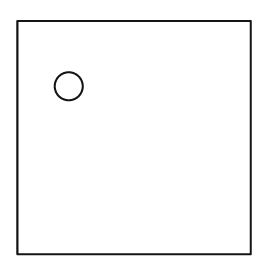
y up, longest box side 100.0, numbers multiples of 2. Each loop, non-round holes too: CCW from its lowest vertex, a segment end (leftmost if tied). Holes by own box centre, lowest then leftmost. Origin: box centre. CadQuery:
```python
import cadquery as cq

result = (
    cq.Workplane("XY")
    .moveTo(-50.0, -50.0)
    .lineTo(50.0, -50.0)
    .lineTo(50.0, 50.0)
    .lineTo(-50.0, 50.0)
    .close()
    .moveTo(-28.0, 22.0)
    .circle(6.0)
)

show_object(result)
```